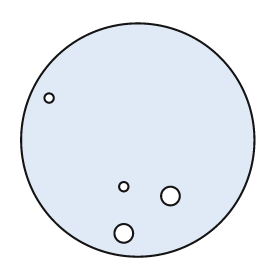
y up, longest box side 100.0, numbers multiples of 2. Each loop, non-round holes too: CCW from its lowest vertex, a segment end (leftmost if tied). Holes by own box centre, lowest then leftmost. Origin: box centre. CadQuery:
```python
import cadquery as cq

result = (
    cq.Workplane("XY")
    .moveTo(0.0, 0.0)
    .circle(50.0)
    .moveTo(-6.0, -40.0)
    .circle(4.0)
    .moveTo(14.0, -24.0)
    .circle(4.0)
    .moveTo(-6.0, -20.0)
    .circle(2.0)
    .moveTo(-38.0, 18.0)
    .circle(2.0)
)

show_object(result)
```